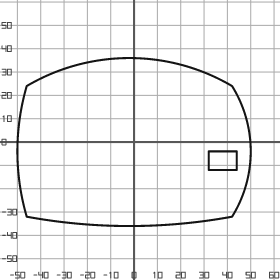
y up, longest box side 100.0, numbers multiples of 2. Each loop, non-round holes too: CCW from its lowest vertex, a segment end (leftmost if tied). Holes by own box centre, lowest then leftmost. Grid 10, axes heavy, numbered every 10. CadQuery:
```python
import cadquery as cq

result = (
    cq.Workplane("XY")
    .moveTo(-46.0, -32.0)
    .threePointArc((-2.0, -36.0), (42.0, -32.0))
    .threePointArc((50.0, -4.0), (42.0, 24.0))
    .threePointArc((-2.0, 36.0), (-46.0, 24.0))
    .threePointArc((-50.0, -4.0), (-46.0, -32.0))
    .close()
    .moveTo(32.0, -12.0)
    .lineTo(44.0, -12.0)
    .lineTo(44.0, -4.0)
    .lineTo(32.0, -4.0)
    .close()
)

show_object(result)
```